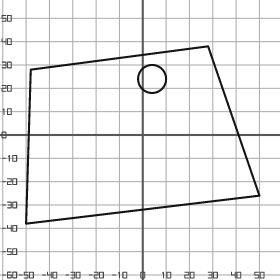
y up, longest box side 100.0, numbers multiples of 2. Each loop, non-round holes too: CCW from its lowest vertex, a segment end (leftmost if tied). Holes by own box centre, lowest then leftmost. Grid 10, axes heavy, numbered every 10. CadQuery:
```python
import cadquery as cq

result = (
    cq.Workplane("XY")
    .moveTo(-50.0, -38.0)
    .lineTo(50.0, -26.0)
    .lineTo(28.0, 38.0)
    .lineTo(-48.0, 28.0)
    .close()
    .moveTo(4.0, 24.0)
    .circle(6.0)
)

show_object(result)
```